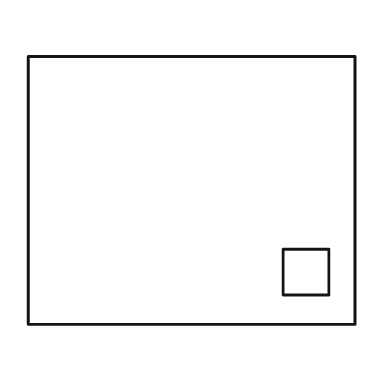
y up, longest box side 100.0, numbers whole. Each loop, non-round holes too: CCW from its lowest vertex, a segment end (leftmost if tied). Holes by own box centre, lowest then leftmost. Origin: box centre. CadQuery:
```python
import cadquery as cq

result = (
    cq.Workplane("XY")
    .moveTo(-50.0, -41.0)
    .lineTo(50.0, -41.0)
    .lineTo(50.0, 41.0)
    .lineTo(-50.0, 41.0)
    .close()
    .moveTo(28.0, -32.0)
    .lineTo(42.0, -32.0)
    .lineTo(42.0, -18.0)
    .lineTo(28.0, -18.0)
    .close()
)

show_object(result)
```